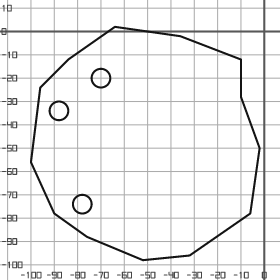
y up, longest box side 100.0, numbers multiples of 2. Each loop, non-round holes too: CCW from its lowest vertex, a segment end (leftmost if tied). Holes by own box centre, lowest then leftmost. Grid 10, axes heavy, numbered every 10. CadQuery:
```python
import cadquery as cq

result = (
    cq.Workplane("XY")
    .moveTo(-52.0, -98.0)
    .lineTo(-32.0, -96.0)
    .lineTo(-6.0, -78.0)
    .lineTo(-2.0, -50.0)
    .lineTo(-10.0, -28.0)
    .lineTo(-10.0, -12.0)
    .lineTo(-36.0, -2.0)
    .lineTo(-64.0, 2.0)
    .lineTo(-84.0, -12.0)
    .lineTo(-96.0, -24.0)
    .lineTo(-100.0, -56.0)
    .lineTo(-90.0, -78.0)
    .lineTo(-76.0, -88.0)
    .close()
    .moveTo(-78.0, -74.0)
    .circle(4.0)
    .moveTo(-88.0, -34.0)
    .circle(4.0)
    .moveTo(-70.0, -20.0)
    .circle(4.0)
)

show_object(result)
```